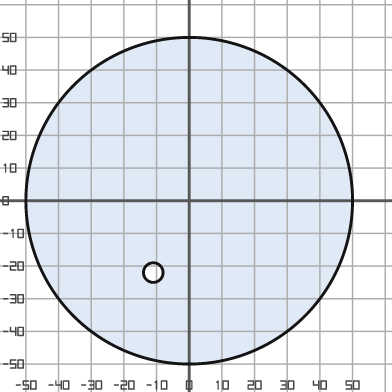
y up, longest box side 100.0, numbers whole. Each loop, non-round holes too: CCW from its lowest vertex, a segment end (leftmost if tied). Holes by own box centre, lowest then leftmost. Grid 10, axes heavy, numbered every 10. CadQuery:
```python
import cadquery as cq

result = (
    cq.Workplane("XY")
    .moveTo(0.0, 0.0)
    .circle(50.0)
    .moveTo(-11.0, -22.0)
    .circle(3.0)
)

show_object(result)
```